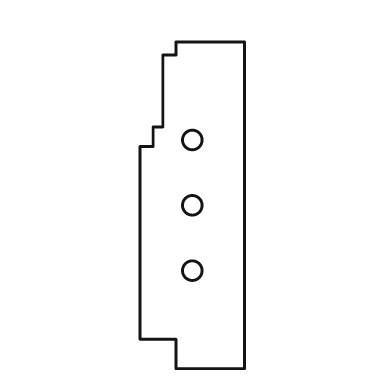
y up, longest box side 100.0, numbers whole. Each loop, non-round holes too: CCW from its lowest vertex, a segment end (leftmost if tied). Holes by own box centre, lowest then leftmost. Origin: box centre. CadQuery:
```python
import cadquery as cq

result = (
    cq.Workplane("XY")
    .moveTo(-5.0, -50.0)
    .lineTo(16.0, -50.0)
    .lineTo(16.0, 50.0)
    .lineTo(-5.0, 50.0)
    .lineTo(-5.0, 46.0)
    .lineTo(-9.0, 46.0)
    .lineTo(-9.0, 24.0)
    .lineTo(-12.0, 24.0)
    .lineTo(-12.0, 18.0)
    .lineTo(-16.0, 18.0)
    .lineTo(-16.0, -41.0)
    .lineTo(-5.0, -41.0)
    .close()
    .moveTo(0.0, -20.0)
    .circle(3.0)
    .moveTo(0.0, 0.0)
    .circle(3.0)
    .moveTo(0.0, 20.0)
    .circle(3.0)
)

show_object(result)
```